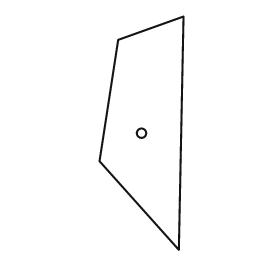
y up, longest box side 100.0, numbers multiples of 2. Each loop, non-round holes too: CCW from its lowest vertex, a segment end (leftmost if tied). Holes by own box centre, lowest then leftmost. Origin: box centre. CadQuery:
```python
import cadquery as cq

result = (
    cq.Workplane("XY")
    .moveTo(16.0, -50.0)
    .lineTo(18.0, 50.0)
    .lineTo(-10.0, 40.0)
    .lineTo(-18.0, -12.0)
    .close()
    .moveTo(0.0, 0.0)
    .circle(2.0)
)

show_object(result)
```